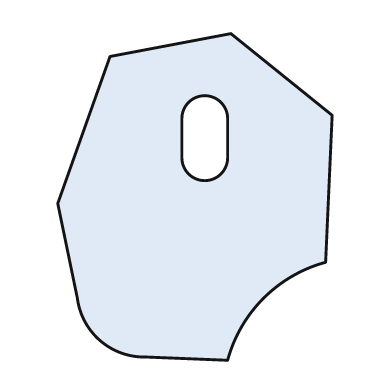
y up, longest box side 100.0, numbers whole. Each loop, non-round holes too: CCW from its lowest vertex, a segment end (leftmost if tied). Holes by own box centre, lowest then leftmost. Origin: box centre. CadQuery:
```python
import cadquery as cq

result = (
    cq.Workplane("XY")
    .moveTo(10.0, -50.0)
    .threePointArc((21.0, -31.0), (40.0, -20.0))
    .lineTo(42.0, 25.0)
    .lineTo(11.0, 50.0)
    .lineTo(-26.0, 43.0)
    .lineTo(-42.0, -2.0)
    .lineTo(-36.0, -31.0)
    .threePointArc((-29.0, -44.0), (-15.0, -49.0))
    .close()
    .moveTo(-4.0, 12.0)
    .threePointArc((3.0, 5.0), (10.0, 12.0))
    .lineTo(10.0, 24.0)
    .threePointArc((3.0, 31.0), (-4.0, 24.0))
    .close()
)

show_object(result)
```